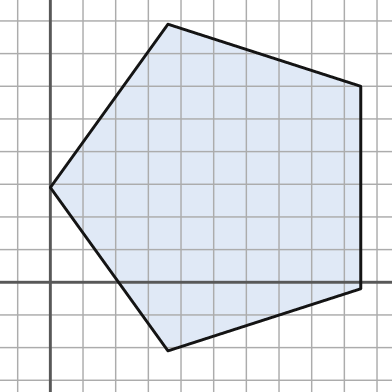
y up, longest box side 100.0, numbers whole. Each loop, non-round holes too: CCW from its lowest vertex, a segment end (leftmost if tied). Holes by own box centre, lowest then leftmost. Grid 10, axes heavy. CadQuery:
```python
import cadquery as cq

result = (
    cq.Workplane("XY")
    .moveTo(36.0, -21.0)
    .lineTo(95.0, -2.0)
    .lineTo(95.0, 60.0)
    .lineTo(36.0, 79.0)
    .lineTo(0.0, 29.0)
    .close()
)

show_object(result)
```